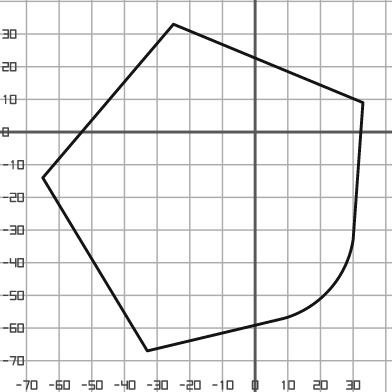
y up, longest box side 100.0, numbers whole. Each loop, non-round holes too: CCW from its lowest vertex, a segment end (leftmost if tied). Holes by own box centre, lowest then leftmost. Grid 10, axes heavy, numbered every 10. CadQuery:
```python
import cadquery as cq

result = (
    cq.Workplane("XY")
    .moveTo(-33.0, -67.0)
    .lineTo(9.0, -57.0)
    .threePointArc((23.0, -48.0), (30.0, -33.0))
    .lineTo(33.0, 9.0)
    .lineTo(-25.0, 33.0)
    .lineTo(-65.0, -14.0)
    .close()
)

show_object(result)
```